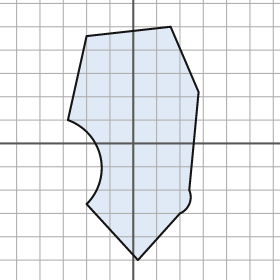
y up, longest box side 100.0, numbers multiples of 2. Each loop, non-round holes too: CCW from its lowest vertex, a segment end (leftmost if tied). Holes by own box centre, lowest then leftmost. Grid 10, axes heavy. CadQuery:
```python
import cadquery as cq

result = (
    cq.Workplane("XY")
    .moveTo(2.0, -50.0)
    .lineTo(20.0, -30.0)
    .threePointArc((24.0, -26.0), (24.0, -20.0))
    .lineTo(28.0, 22.0)
    .lineTo(16.0, 50.0)
    .lineTo(-20.0, 46.0)
    .lineTo(-28.0, 10.0)
    .threePointArc((-14.0, -6.0), (-20.0, -26.0))
    .close()
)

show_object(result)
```